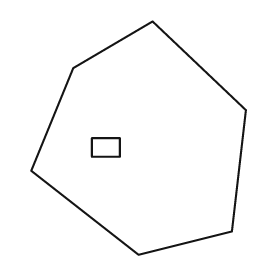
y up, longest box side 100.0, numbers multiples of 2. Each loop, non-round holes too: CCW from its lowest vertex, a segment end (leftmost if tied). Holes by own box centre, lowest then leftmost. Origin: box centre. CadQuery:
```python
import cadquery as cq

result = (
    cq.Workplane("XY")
    .moveTo(0.0, -50.0)
    .lineTo(40.0, -40.0)
    .lineTo(46.0, 12.0)
    .lineTo(6.0, 50.0)
    .lineTo(-28.0, 30.0)
    .lineTo(-46.0, -14.0)
    .close()
    .moveTo(-20.0, -8.0)
    .lineTo(-8.0, -8.0)
    .lineTo(-8.0, 0.0)
    .lineTo(-20.0, 0.0)
    .close()
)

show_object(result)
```